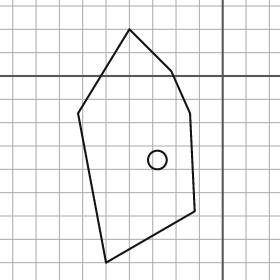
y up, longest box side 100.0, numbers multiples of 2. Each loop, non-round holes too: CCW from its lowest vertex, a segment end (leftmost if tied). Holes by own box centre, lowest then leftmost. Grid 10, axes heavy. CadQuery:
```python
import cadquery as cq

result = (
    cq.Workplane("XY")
    .moveTo(-50.0, -80.0)
    .lineTo(-12.0, -58.0)
    .lineTo(-14.0, -16.0)
    .lineTo(-22.0, 2.0)
    .lineTo(-40.0, 20.0)
    .lineTo(-62.0, -16.0)
    .close()
    .moveTo(-28.0, -36.0)
    .circle(4.0)
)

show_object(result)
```